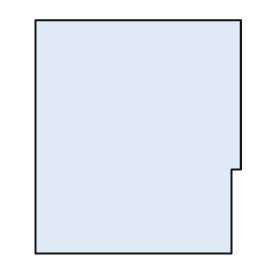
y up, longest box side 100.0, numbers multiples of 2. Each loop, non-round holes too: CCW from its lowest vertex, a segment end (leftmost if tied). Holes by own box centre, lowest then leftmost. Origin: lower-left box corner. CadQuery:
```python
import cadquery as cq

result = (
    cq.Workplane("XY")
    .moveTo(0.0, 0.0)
    .lineTo(84.0, 0.0)
    .lineTo(84.0, 36.0)
    .lineTo(88.0, 36.0)
    .lineTo(88.0, 100.0)
    .lineTo(0.0, 100.0)
    .close()
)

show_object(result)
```